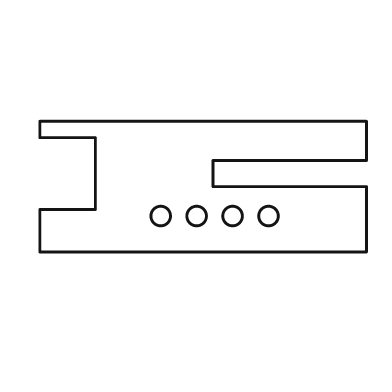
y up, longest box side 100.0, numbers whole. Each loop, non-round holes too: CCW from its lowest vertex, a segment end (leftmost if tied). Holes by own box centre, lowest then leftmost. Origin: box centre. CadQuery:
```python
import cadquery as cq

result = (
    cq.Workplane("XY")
    .moveTo(-50.0, -20.0)
    .lineTo(50.0, -20.0)
    .lineTo(50.0, 0.0)
    .lineTo(3.0, 0.0)
    .lineTo(3.0, 8.0)
    .lineTo(50.0, 8.0)
    .lineTo(50.0, 20.0)
    .lineTo(-50.0, 20.0)
    .lineTo(-50.0, 15.0)
    .lineTo(-33.0, 15.0)
    .lineTo(-33.0, -7.0)
    .lineTo(-50.0, -7.0)
    .close()
    .moveTo(-13.0, -9.0)
    .circle(3.0)
    .moveTo(-2.0, -9.0)
    .circle(3.0)
    .moveTo(9.0, -9.0)
    .circle(3.0)
    .moveTo(20.0, -9.0)
    .circle(3.0)
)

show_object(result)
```